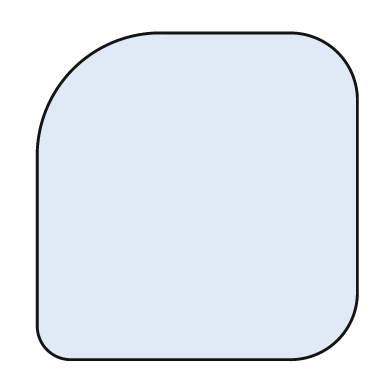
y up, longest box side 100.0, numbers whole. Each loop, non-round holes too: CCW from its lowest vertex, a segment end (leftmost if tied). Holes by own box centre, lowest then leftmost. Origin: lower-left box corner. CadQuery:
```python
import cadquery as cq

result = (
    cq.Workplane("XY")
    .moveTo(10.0, 0.0)
    .lineTo(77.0, 0.0)
    .threePointArc((92.0, 6.0), (98.0, 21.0))
    .lineTo(98.0, 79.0)
    .threePointArc((92.0, 94.0), (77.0, 100.0))
    .lineTo(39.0, 100.0)
    .threePointArc((11.0, 89.0), (0.0, 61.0))
    .lineTo(0.0, 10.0)
    .threePointArc((3.0, 3.0), (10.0, 0.0))
    .close()
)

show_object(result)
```